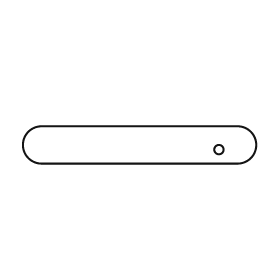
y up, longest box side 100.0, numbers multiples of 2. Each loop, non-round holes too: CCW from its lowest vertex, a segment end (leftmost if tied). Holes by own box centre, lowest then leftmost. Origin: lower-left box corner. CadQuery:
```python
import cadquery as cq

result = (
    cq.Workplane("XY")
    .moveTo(8.0, 0.0)
    .lineTo(92.0, 0.0)
    .threePointArc((100.0, 8.0), (92.0, 16.0))
    .lineTo(8.0, 16.0)
    .threePointArc((0.0, 8.0), (8.0, 0.0))
    .close()
    .moveTo(84.0, 6.0)
    .circle(2.0)
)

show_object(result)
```